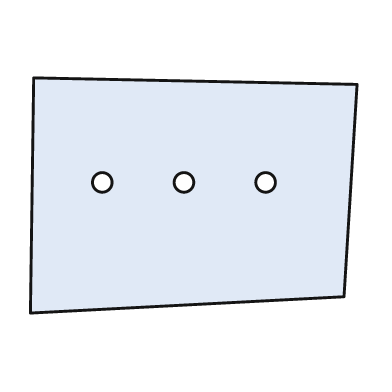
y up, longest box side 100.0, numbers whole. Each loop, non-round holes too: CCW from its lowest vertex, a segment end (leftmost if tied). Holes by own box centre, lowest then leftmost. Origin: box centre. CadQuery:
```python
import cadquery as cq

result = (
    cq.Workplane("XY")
    .moveTo(-50.0, -36.0)
    .lineTo(46.0, -31.0)
    .lineTo(50.0, 34.0)
    .lineTo(-49.0, 36.0)
    .close()
    .moveTo(-28.0, 4.0)
    .circle(3.0)
    .moveTo(-3.0, 4.0)
    .circle(3.0)
    .moveTo(22.0, 4.0)
    .circle(3.0)
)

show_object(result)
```